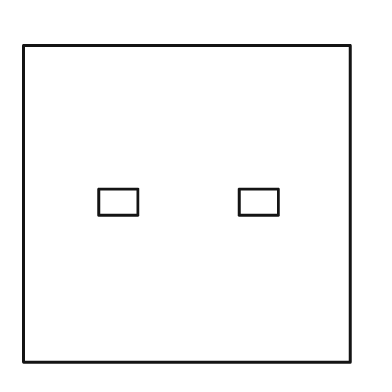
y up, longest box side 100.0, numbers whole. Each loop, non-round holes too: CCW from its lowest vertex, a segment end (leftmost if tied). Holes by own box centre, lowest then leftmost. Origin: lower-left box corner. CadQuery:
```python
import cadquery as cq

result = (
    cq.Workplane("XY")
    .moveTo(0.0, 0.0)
    .lineTo(100.0, 0.0)
    .lineTo(100.0, 97.0)
    .lineTo(0.0, 97.0)
    .close()
    .moveTo(23.0, 45.0)
    .lineTo(35.0, 45.0)
    .lineTo(35.0, 53.0)
    .lineTo(23.0, 53.0)
    .close()
    .moveTo(66.0, 45.0)
    .lineTo(78.0, 45.0)
    .lineTo(78.0, 53.0)
    .lineTo(66.0, 53.0)
    .close()
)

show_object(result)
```